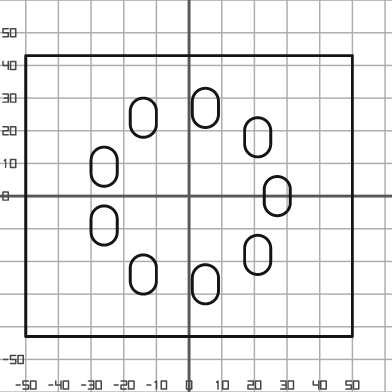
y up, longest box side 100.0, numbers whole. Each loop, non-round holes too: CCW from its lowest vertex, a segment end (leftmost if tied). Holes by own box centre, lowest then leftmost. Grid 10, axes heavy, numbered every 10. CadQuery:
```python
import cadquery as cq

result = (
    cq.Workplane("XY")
    .moveTo(-50.0, -43.0)
    .lineTo(50.0, -43.0)
    .lineTo(50.0, 43.0)
    .lineTo(-50.0, 43.0)
    .close()
    .moveTo(1.0, -29.0)
    .threePointArc((5.0, -33.0), (9.0, -29.0))
    .lineTo(9.0, -25.0)
    .threePointArc((5.0, -21.0), (1.0, -25.0))
    .close()
    .moveTo(-18.0, -26.0)
    .threePointArc((-14.0, -30.0), (-10.0, -26.0))
    .lineTo(-10.0, -22.0)
    .threePointArc((-14.0, -18.0), (-18.0, -22.0))
    .close()
    .moveTo(17.0, -20.0)
    .threePointArc((21.0, -24.0), (25.0, -20.0))
    .lineTo(25.0, -16.0)
    .threePointArc((21.0, -12.0), (17.0, -16.0))
    .close()
    .moveTo(-30.0, -11.0)
    .threePointArc((-26.0, -15.0), (-22.0, -11.0))
    .lineTo(-22.0, -7.0)
    .threePointArc((-26.0, -3.0), (-30.0, -7.0))
    .close()
    .moveTo(23.0, -2.0)
    .threePointArc((27.0, -6.0), (31.0, -2.0))
    .lineTo(31.0, 2.0)
    .threePointArc((27.0, 6.0), (23.0, 2.0))
    .close()
    .moveTo(-30.0, 7.0)
    .threePointArc((-26.0, 3.0), (-22.0, 7.0))
    .lineTo(-22.0, 11.0)
    .threePointArc((-26.0, 15.0), (-30.0, 11.0))
    .close()
    .moveTo(17.0, 16.0)
    .threePointArc((21.0, 12.0), (25.0, 16.0))
    .lineTo(25.0, 20.0)
    .threePointArc((21.0, 24.0), (17.0, 20.0))
    .close()
    .moveTo(-18.0, 22.0)
    .threePointArc((-14.0, 18.0), (-10.0, 22.0))
    .lineTo(-10.0, 26.0)
    .threePointArc((-14.0, 30.0), (-18.0, 26.0))
    .close()
    .moveTo(1.0, 25.0)
    .threePointArc((5.0, 21.0), (9.0, 25.0))
    .lineTo(9.0, 29.0)
    .threePointArc((5.0, 33.0), (1.0, 29.0))
    .close()
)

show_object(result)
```